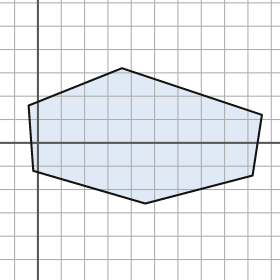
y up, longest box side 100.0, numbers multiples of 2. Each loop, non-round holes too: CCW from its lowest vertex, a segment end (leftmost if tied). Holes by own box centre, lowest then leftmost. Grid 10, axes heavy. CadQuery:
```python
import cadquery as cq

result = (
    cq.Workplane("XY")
    .moveTo(46.0, -26.0)
    .lineTo(92.0, -14.0)
    .lineTo(96.0, 12.0)
    .lineTo(36.0, 32.0)
    .lineTo(-4.0, 16.0)
    .lineTo(-2.0, -12.0)
    .close()
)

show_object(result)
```